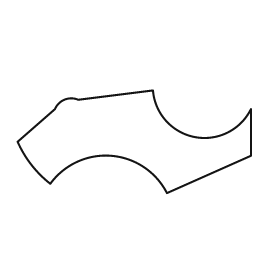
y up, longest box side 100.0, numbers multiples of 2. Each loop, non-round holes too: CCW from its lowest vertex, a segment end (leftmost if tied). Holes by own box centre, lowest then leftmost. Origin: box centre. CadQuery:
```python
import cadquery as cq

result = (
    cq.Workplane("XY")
    .moveTo(14.0, -22.0)
    .lineTo(50.0, -6.0)
    .lineTo(50.0, 14.0)
    .threePointArc((26.0, 2.0), (8.0, 22.0))
    .lineTo(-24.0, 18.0)
    .threePointArc((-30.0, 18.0), (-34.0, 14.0))
    .lineTo(-50.0, 0.0)
    .threePointArc((-44.0, -10.0), (-36.0, -18.0))
    .threePointArc((-10.0, -6.0), (14.0, -22.0))
    .close()
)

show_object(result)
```